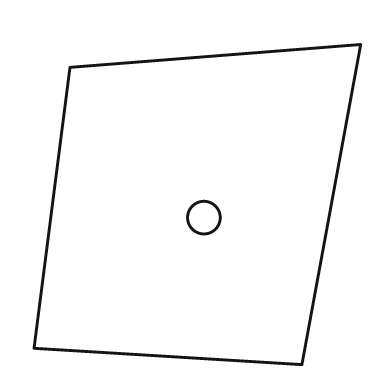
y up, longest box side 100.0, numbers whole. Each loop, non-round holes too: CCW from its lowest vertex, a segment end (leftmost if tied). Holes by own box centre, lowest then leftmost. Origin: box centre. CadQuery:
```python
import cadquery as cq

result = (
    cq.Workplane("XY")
    .moveTo(32.0, -49.0)
    .lineTo(50.0, 49.0)
    .lineTo(-39.0, 42.0)
    .lineTo(-50.0, -44.0)
    .close()
    .moveTo(2.0, -4.0)
    .circle(5.0)
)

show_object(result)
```